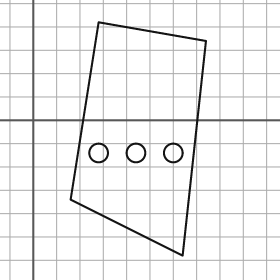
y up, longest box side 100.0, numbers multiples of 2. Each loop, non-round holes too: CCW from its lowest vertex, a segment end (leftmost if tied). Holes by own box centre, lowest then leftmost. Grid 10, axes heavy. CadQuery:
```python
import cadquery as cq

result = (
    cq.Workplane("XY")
    .moveTo(64.0, -58.0)
    .lineTo(74.0, 34.0)
    .lineTo(28.0, 42.0)
    .lineTo(16.0, -34.0)
    .close()
    .moveTo(28.0, -14.0)
    .circle(4.0)
    .moveTo(44.0, -14.0)
    .circle(4.0)
    .moveTo(60.0, -14.0)
    .circle(4.0)
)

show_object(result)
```